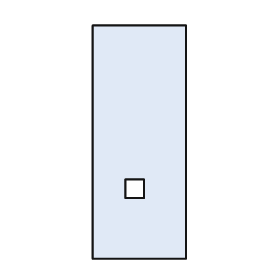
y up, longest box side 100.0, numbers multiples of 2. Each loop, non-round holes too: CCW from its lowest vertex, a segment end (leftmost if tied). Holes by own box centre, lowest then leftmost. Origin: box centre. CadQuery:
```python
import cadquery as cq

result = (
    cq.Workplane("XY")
    .moveTo(-20.0, -50.0)
    .lineTo(20.0, -50.0)
    .lineTo(20.0, 50.0)
    .lineTo(-20.0, 50.0)
    .close()
    .moveTo(-6.0, -24.0)
    .lineTo(2.0, -24.0)
    .lineTo(2.0, -16.0)
    .lineTo(-6.0, -16.0)
    .close()
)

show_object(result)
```